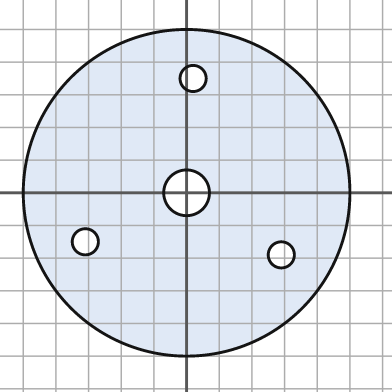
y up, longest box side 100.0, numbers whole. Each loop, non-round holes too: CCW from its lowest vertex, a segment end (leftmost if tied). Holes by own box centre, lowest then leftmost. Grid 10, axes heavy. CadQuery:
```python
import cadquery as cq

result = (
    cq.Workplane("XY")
    .moveTo(0.0, 0.0)
    .circle(50.0)
    .moveTo(29.0, -19.0)
    .circle(4.0)
    .moveTo(-31.0, -15.0)
    .circle(4.0)
    .moveTo(0.0, 0.0)
    .circle(7.0)
    .moveTo(2.0, 35.0)
    .circle(4.0)
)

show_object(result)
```